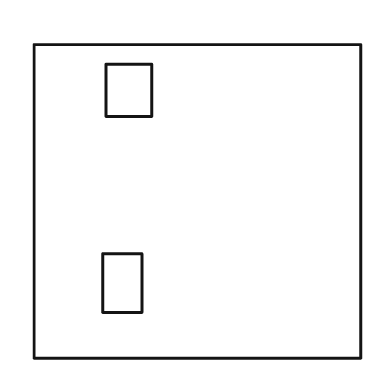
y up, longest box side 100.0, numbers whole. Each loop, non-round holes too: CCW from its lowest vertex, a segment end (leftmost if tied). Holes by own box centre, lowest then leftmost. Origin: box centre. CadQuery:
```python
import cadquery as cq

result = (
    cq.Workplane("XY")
    .moveTo(-50.0, -48.0)
    .lineTo(50.0, -48.0)
    .lineTo(50.0, 48.0)
    .lineTo(-50.0, 48.0)
    .close()
    .moveTo(-29.0, -34.0)
    .lineTo(-17.0, -34.0)
    .lineTo(-17.0, -16.0)
    .lineTo(-29.0, -16.0)
    .close()
    .moveTo(-28.0, 26.0)
    .lineTo(-14.0, 26.0)
    .lineTo(-14.0, 42.0)
    .lineTo(-28.0, 42.0)
    .close()
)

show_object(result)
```